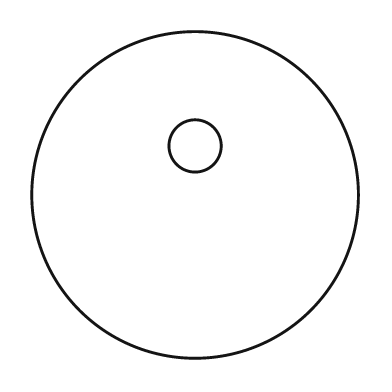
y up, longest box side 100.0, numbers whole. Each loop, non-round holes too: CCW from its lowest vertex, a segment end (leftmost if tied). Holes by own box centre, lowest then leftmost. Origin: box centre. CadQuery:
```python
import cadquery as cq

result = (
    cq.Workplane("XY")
    .moveTo(0.0, 0.0)
    .circle(50.0)
    .moveTo(0.0, 15.0)
    .circle(8.0)
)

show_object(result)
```